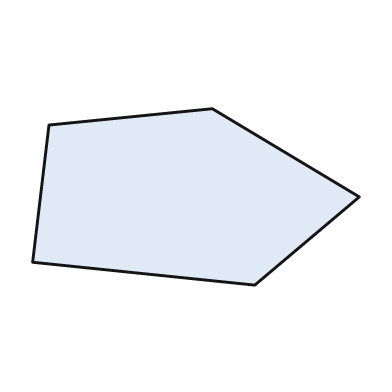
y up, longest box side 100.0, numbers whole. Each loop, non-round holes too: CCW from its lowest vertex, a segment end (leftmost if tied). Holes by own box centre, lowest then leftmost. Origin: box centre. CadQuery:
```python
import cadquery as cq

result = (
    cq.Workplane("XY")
    .moveTo(18.0, -27.0)
    .lineTo(50.0, 0.0)
    .lineTo(5.0, 27.0)
    .lineTo(-45.0, 22.0)
    .lineTo(-50.0, -20.0)
    .close()
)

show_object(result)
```